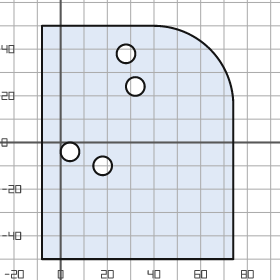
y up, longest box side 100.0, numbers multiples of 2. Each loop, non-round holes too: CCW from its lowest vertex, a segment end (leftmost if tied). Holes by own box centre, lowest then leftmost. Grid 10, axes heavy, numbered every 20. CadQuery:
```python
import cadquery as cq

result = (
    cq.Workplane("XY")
    .moveTo(-8.0, -50.0)
    .lineTo(74.0, -50.0)
    .lineTo(74.0, 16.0)
    .threePointArc((64.0, 40.0), (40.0, 50.0))
    .lineTo(-8.0, 50.0)
    .close()
    .moveTo(18.0, -10.0)
    .circle(4.0)
    .moveTo(4.0, -4.0)
    .circle(4.0)
    .moveTo(32.0, 24.0)
    .circle(4.0)
    .moveTo(28.0, 38.0)
    .circle(4.0)
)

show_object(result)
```